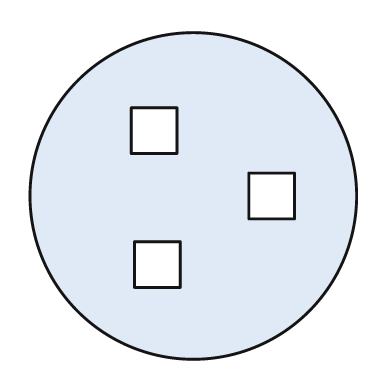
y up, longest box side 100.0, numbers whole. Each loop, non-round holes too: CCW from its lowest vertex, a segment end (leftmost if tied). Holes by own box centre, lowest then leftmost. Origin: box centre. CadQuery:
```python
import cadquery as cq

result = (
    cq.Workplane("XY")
    .moveTo(0.0, 0.0)
    .circle(50.0)
    .moveTo(-18.0, -28.0)
    .lineTo(-4.0, -28.0)
    .lineTo(-4.0, -14.0)
    .lineTo(-18.0, -14.0)
    .close()
    .moveTo(17.0, -7.0)
    .lineTo(31.0, -7.0)
    .lineTo(31.0, 7.0)
    .lineTo(17.0, 7.0)
    .close()
    .moveTo(-19.0, 13.0)
    .lineTo(-5.0, 13.0)
    .lineTo(-5.0, 27.0)
    .lineTo(-19.0, 27.0)
    .close()
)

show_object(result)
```